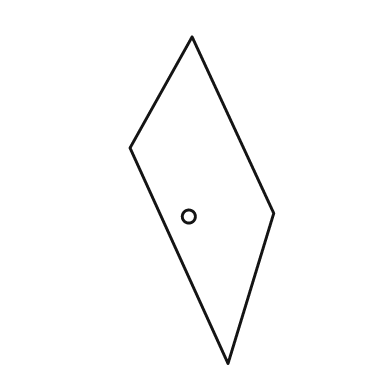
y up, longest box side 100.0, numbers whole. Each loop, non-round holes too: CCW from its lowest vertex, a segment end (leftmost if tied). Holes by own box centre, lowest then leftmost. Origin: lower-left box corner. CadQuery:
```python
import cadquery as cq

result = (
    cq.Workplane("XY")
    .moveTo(30.0, 0.0)
    .lineTo(44.0, 46.0)
    .lineTo(19.0, 100.0)
    .lineTo(0.0, 66.0)
    .close()
    .moveTo(18.0, 45.0)
    .circle(2.0)
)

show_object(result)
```